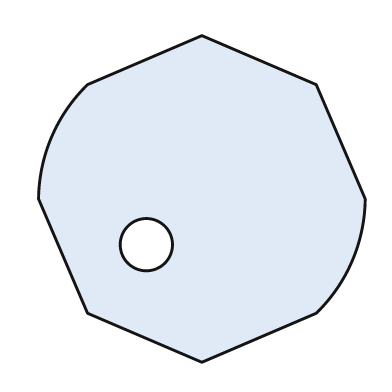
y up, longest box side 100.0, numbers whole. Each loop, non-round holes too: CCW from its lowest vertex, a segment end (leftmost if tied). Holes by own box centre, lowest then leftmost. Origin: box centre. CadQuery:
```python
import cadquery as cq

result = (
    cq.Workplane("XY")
    .moveTo(0.0, -50.0)
    .lineTo(35.0, -35.0)
    .threePointArc((46.0, -19.0), (50.0, 0.0))
    .lineTo(35.0, 35.0)
    .lineTo(0.0, 50.0)
    .lineTo(-35.0, 35.0)
    .threePointArc((-46.0, 19.0), (-50.0, 0.0))
    .lineTo(-35.0, -35.0)
    .close()
    .moveTo(-17.0, -14.0)
    .circle(8.0)
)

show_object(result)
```